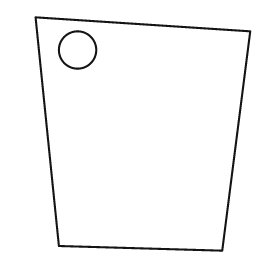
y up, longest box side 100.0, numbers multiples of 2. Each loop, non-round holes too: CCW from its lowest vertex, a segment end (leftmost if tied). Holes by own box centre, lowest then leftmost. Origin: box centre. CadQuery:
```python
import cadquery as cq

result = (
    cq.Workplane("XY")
    .moveTo(34.0, -50.0)
    .lineTo(46.0, 44.0)
    .lineTo(-46.0, 50.0)
    .lineTo(-36.0, -48.0)
    .close()
    .moveTo(-28.0, 36.0)
    .circle(8.0)
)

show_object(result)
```